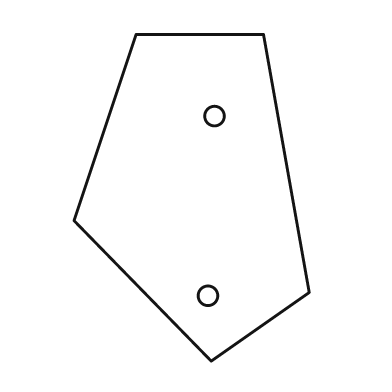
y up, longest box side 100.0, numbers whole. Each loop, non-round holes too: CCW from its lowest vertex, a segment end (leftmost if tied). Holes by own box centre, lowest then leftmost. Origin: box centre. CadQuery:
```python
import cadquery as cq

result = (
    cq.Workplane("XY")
    .moveTo(6.0, -50.0)
    .lineTo(36.0, -29.0)
    .lineTo(22.0, 50.0)
    .lineTo(-17.0, 50.0)
    .lineTo(-36.0, -7.0)
    .close()
    .moveTo(5.0, -30.0)
    .circle(3.0)
    .moveTo(7.0, 25.0)
    .circle(3.0)
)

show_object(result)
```